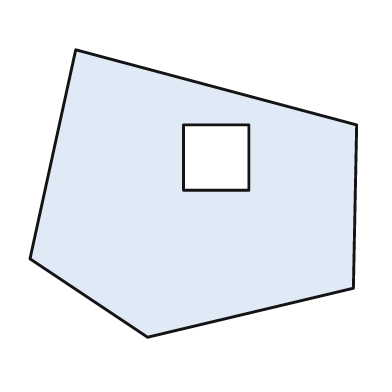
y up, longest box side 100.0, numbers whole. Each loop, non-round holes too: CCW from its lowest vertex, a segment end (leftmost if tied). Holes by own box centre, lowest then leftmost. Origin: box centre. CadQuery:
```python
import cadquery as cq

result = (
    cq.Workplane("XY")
    .moveTo(-14.0, -44.0)
    .lineTo(49.0, -29.0)
    .lineTo(50.0, 21.0)
    .lineTo(-36.0, 44.0)
    .lineTo(-50.0, -20.0)
    .close()
    .moveTo(-3.0, 1.0)
    .lineTo(17.0, 1.0)
    .lineTo(17.0, 21.0)
    .lineTo(-3.0, 21.0)
    .close()
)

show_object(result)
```